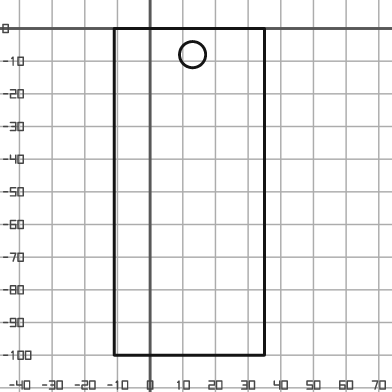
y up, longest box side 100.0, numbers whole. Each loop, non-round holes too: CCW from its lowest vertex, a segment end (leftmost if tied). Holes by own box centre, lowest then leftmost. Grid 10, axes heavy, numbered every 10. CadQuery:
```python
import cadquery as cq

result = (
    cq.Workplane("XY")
    .moveTo(-11.0, -100.0)
    .lineTo(35.0, -100.0)
    .lineTo(35.0, 0.0)
    .lineTo(-11.0, 0.0)
    .close()
    .moveTo(13.0, -8.0)
    .circle(4.0)
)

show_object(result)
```